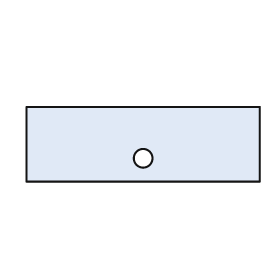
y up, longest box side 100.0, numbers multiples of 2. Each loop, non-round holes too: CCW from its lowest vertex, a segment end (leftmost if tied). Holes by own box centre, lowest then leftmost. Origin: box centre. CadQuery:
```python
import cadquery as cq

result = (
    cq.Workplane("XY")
    .moveTo(-50.0, -16.0)
    .lineTo(50.0, -16.0)
    .lineTo(50.0, 16.0)
    .lineTo(-50.0, 16.0)
    .close()
    .moveTo(0.0, -6.0)
    .circle(4.0)
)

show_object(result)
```